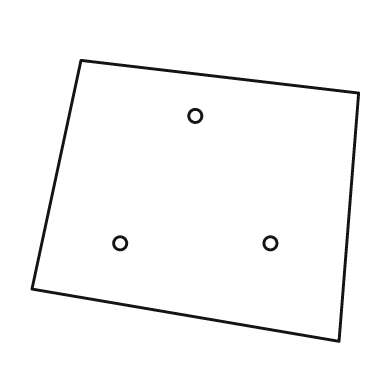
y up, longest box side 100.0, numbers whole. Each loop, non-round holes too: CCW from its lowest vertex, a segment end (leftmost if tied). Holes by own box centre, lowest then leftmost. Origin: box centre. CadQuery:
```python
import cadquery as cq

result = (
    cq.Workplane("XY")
    .moveTo(44.0, -43.0)
    .lineTo(50.0, 33.0)
    .lineTo(-35.0, 43.0)
    .lineTo(-50.0, -27.0)
    .close()
    .moveTo(-23.0, -13.0)
    .circle(2.0)
    .moveTo(23.0, -13.0)
    .circle(2.0)
    .moveTo(0.0, 26.0)
    .circle(2.0)
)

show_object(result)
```